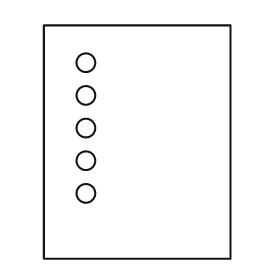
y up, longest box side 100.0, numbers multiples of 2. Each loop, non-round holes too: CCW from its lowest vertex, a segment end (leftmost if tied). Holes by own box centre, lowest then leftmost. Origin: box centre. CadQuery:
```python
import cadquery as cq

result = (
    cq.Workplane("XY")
    .moveTo(-40.0, -50.0)
    .lineTo(40.0, -50.0)
    .lineTo(40.0, 50.0)
    .lineTo(-40.0, 50.0)
    .close()
    .moveTo(-22.0, -22.0)
    .circle(4.0)
    .moveTo(-22.0, -8.0)
    .circle(4.0)
    .moveTo(-22.0, 6.0)
    .circle(4.0)
    .moveTo(-22.0, 20.0)
    .circle(4.0)
    .moveTo(-22.0, 34.0)
    .circle(4.0)
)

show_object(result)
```